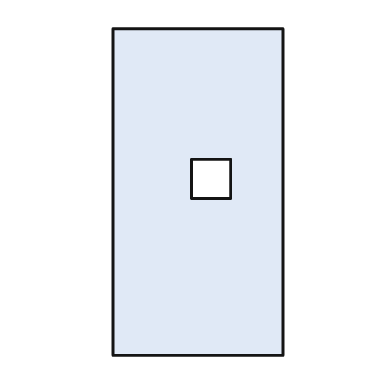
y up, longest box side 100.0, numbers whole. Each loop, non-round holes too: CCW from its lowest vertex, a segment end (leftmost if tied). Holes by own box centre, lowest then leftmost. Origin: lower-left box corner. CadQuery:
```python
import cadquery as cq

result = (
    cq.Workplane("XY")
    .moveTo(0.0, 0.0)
    .lineTo(52.0, 0.0)
    .lineTo(52.0, 100.0)
    .lineTo(0.0, 100.0)
    .close()
    .moveTo(24.0, 48.0)
    .lineTo(36.0, 48.0)
    .lineTo(36.0, 60.0)
    .lineTo(24.0, 60.0)
    .close()
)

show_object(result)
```